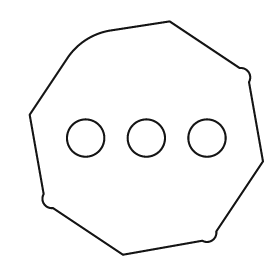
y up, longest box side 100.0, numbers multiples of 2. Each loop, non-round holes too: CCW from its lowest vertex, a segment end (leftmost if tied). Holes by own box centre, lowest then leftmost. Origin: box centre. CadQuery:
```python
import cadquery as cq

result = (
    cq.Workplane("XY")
    .moveTo(-10.0, -50.0)
    .lineTo(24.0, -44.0)
    .threePointArc((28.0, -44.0), (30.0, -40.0))
    .lineTo(50.0, -10.0)
    .lineTo(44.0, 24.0)
    .threePointArc((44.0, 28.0), (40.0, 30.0))
    .lineTo(10.0, 50.0)
    .lineTo(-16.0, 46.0)
    .threePointArc((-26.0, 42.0), (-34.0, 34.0))
    .lineTo(-50.0, 10.0)
    .lineTo(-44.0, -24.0)
    .threePointArc((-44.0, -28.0), (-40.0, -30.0))
    .close()
    .moveTo(-26.0, 0.0)
    .circle(8.0)
    .moveTo(0.0, 0.0)
    .circle(8.0)
    .moveTo(26.0, 0.0)
    .circle(8.0)
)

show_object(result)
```